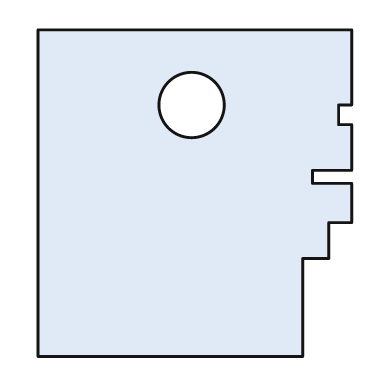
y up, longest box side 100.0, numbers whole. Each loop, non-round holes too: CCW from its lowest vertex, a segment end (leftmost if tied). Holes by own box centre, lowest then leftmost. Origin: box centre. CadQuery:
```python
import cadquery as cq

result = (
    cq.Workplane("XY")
    .moveTo(-48.0, -50.0)
    .lineTo(33.0, -50.0)
    .lineTo(33.0, -20.0)
    .lineTo(41.0, -20.0)
    .lineTo(41.0, -9.0)
    .lineTo(48.0, -9.0)
    .lineTo(48.0, 3.0)
    .lineTo(36.0, 3.0)
    .lineTo(36.0, 7.0)
    .lineTo(48.0, 7.0)
    .lineTo(48.0, 21.0)
    .lineTo(44.0, 21.0)
    .lineTo(44.0, 27.0)
    .lineTo(48.0, 27.0)
    .lineTo(48.0, 50.0)
    .lineTo(-48.0, 50.0)
    .close()
    .moveTo(-1.0, 27.0)
    .circle(10.0)
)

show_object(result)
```